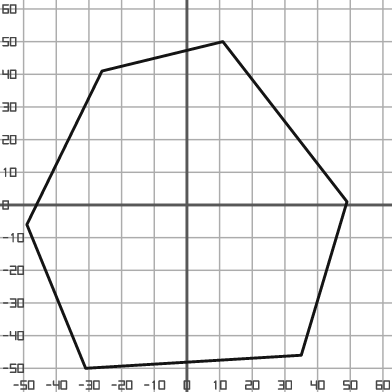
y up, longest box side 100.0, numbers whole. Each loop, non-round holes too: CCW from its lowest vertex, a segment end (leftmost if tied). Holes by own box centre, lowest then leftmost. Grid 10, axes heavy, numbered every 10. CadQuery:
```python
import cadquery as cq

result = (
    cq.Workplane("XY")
    .moveTo(-31.0, -50.0)
    .lineTo(35.0, -46.0)
    .lineTo(49.0, 1.0)
    .lineTo(11.0, 50.0)
    .lineTo(-26.0, 41.0)
    .lineTo(-49.0, -6.0)
    .close()
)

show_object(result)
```